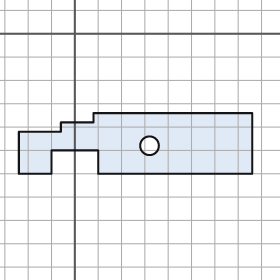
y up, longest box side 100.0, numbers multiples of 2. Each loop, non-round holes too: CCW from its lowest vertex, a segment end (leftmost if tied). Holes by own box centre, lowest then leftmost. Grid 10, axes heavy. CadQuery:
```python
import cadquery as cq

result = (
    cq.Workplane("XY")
    .moveTo(-24.0, -60.0)
    .lineTo(-10.0, -60.0)
    .lineTo(-10.0, -50.0)
    .lineTo(10.0, -50.0)
    .lineTo(10.0, -60.0)
    .lineTo(76.0, -60.0)
    .lineTo(76.0, -34.0)
    .lineTo(8.0, -34.0)
    .lineTo(8.0, -38.0)
    .lineTo(-6.0, -38.0)
    .lineTo(-6.0, -42.0)
    .lineTo(-24.0, -42.0)
    .close()
    .moveTo(32.0, -48.0)
    .circle(4.0)
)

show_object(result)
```